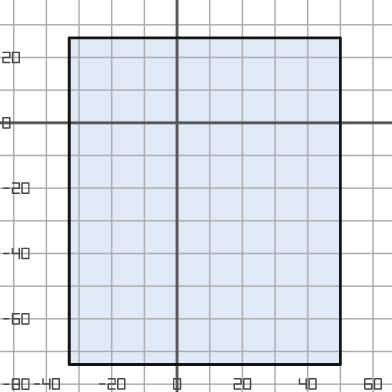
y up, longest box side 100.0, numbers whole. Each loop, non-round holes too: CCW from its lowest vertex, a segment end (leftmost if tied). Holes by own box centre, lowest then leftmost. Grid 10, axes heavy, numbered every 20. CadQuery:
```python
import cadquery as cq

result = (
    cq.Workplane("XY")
    .moveTo(-33.0, -74.0)
    .lineTo(50.0, -74.0)
    .lineTo(50.0, 26.0)
    .lineTo(-33.0, 26.0)
    .close()
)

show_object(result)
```